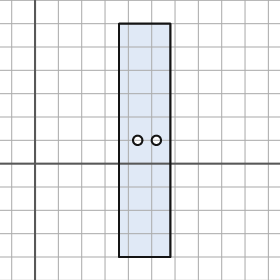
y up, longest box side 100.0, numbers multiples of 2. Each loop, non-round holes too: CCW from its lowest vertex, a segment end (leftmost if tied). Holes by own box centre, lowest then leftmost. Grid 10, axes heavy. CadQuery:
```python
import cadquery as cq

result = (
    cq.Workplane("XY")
    .moveTo(36.0, -40.0)
    .lineTo(58.0, -40.0)
    .lineTo(58.0, 60.0)
    .lineTo(36.0, 60.0)
    .close()
    .moveTo(44.0, 10.0)
    .circle(2.0)
    .moveTo(52.0, 10.0)
    .circle(2.0)
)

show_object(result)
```